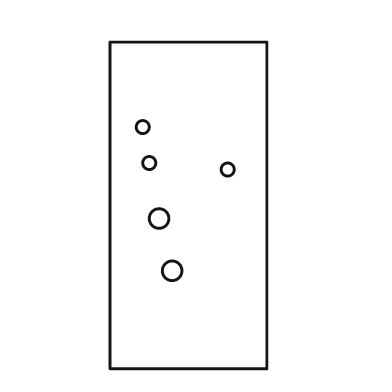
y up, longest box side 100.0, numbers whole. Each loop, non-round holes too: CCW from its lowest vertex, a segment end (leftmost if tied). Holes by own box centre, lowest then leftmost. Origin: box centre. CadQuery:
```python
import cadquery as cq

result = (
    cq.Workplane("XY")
    .moveTo(-24.0, -50.0)
    .lineTo(24.0, -50.0)
    .lineTo(24.0, 50.0)
    .lineTo(-24.0, 50.0)
    .close()
    .moveTo(-5.0, -20.0)
    .circle(3.0)
    .moveTo(-9.0, -4.0)
    .circle(3.0)
    .moveTo(12.0, 11.0)
    .circle(2.0)
    .moveTo(-12.0, 13.0)
    .circle(2.0)
    .moveTo(-14.0, 24.0)
    .circle(2.0)
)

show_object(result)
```